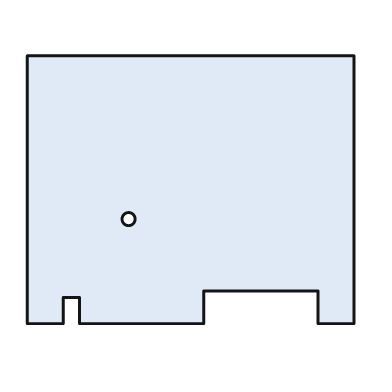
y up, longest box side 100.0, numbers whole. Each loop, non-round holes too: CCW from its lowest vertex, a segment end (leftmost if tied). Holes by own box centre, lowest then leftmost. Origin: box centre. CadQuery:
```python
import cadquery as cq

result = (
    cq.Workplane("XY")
    .moveTo(-50.0, -41.0)
    .lineTo(-39.0, -41.0)
    .lineTo(-39.0, -33.0)
    .lineTo(-34.0, -33.0)
    .lineTo(-34.0, -41.0)
    .lineTo(4.0, -41.0)
    .lineTo(4.0, -31.0)
    .lineTo(39.0, -31.0)
    .lineTo(39.0, -41.0)
    .lineTo(50.0, -41.0)
    .lineTo(50.0, 41.0)
    .lineTo(-50.0, 41.0)
    .close()
    .moveTo(-19.0, -9.0)
    .circle(2.0)
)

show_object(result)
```